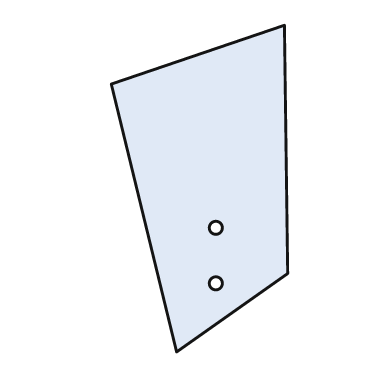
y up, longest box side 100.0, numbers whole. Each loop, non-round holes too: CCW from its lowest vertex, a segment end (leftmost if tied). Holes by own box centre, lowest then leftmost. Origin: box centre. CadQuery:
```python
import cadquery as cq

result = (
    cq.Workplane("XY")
    .moveTo(-7.0, -50.0)
    .lineTo(27.0, -26.0)
    .lineTo(26.0, 50.0)
    .lineTo(-27.0, 32.0)
    .close()
    .moveTo(5.0, -29.0)
    .circle(2.0)
    .moveTo(5.0, -12.0)
    .circle(2.0)
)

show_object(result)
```